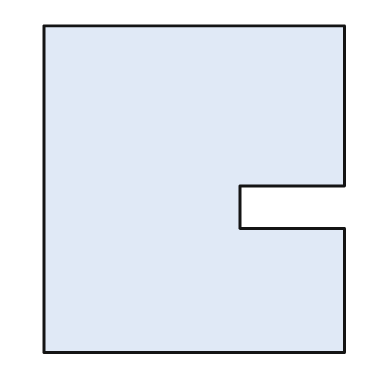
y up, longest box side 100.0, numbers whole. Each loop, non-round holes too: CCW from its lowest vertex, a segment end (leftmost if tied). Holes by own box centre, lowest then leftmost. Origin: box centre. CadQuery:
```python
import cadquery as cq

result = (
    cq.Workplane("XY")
    .moveTo(-46.0, -50.0)
    .lineTo(46.0, -50.0)
    .lineTo(46.0, -12.0)
    .lineTo(14.0, -12.0)
    .lineTo(14.0, 1.0)
    .lineTo(46.0, 1.0)
    .lineTo(46.0, 50.0)
    .lineTo(-46.0, 50.0)
    .close()
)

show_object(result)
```